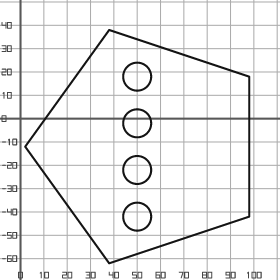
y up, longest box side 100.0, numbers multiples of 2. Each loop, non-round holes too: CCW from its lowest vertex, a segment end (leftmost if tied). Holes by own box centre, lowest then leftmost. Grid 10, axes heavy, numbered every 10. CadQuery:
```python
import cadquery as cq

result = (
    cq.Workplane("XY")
    .moveTo(38.0, -62.0)
    .lineTo(98.0, -42.0)
    .lineTo(98.0, 18.0)
    .lineTo(38.0, 38.0)
    .lineTo(2.0, -12.0)
    .close()
    .moveTo(50.0, -42.0)
    .circle(6.0)
    .moveTo(50.0, -22.0)
    .circle(6.0)
    .moveTo(50.0, -2.0)
    .circle(6.0)
    .moveTo(50.0, 18.0)
    .circle(6.0)
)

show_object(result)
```